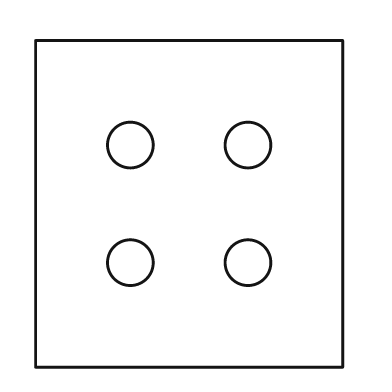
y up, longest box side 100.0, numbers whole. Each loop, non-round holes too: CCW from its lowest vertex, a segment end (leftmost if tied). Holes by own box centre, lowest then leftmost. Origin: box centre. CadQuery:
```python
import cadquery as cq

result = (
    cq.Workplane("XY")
    .moveTo(-47.0, -50.0)
    .lineTo(47.0, -50.0)
    .lineTo(47.0, 50.0)
    .lineTo(-47.0, 50.0)
    .close()
    .moveTo(-18.0, -18.0)
    .circle(7.0)
    .moveTo(18.0, -18.0)
    .circle(7.0)
    .moveTo(-18.0, 18.0)
    .circle(7.0)
    .moveTo(18.0, 18.0)
    .circle(7.0)
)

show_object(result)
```